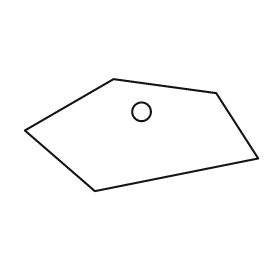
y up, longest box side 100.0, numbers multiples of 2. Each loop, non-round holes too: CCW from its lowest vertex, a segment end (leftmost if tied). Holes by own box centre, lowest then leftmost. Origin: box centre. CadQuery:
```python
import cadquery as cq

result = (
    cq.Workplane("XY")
    .moveTo(-20.0, -24.0)
    .lineTo(50.0, -10.0)
    .lineTo(32.0, 18.0)
    .lineTo(-12.0, 24.0)
    .lineTo(-50.0, 2.0)
    .close()
    .moveTo(0.0, 10.0)
    .circle(4.0)
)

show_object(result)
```